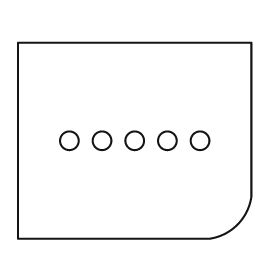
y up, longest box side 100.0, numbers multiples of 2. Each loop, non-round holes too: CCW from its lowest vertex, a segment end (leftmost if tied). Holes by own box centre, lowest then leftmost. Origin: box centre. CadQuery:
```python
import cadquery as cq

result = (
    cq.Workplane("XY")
    .moveTo(-50.0, -42.0)
    .lineTo(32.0, -42.0)
    .threePointArc((44.0, -36.0), (50.0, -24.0))
    .lineTo(50.0, 42.0)
    .lineTo(-50.0, 42.0)
    .close()
    .moveTo(-28.0, 0.0)
    .circle(4.0)
    .moveTo(-14.0, 0.0)
    .circle(4.0)
    .moveTo(0.0, 0.0)
    .circle(4.0)
    .moveTo(14.0, 0.0)
    .circle(4.0)
    .moveTo(28.0, 0.0)
    .circle(4.0)
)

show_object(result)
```